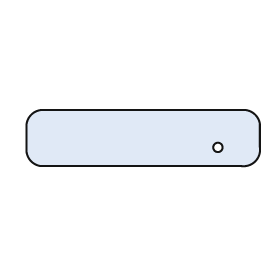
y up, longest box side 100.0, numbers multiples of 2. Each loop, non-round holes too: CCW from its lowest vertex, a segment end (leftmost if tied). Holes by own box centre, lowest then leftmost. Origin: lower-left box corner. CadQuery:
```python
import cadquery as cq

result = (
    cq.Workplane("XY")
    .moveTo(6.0, 0.0)
    .lineTo(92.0, 0.0)
    .threePointArc((98.0, 2.0), (100.0, 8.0))
    .lineTo(100.0, 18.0)
    .threePointArc((98.0, 22.0), (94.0, 24.0))
    .lineTo(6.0, 24.0)
    .threePointArc((2.0, 22.0), (0.0, 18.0))
    .lineTo(0.0, 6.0)
    .threePointArc((2.0, 2.0), (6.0, 0.0))
    .close()
    .moveTo(82.0, 8.0)
    .circle(2.0)
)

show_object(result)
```